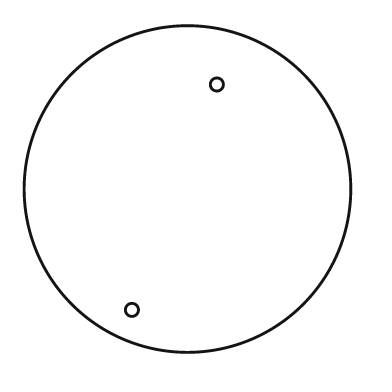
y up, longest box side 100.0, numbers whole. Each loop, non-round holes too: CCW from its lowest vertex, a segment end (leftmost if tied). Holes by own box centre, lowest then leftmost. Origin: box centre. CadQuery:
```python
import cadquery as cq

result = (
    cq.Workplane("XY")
    .moveTo(0.0, 0.0)
    .circle(50.0)
    .moveTo(-17.0, -37.0)
    .circle(2.0)
    .moveTo(9.0, 32.0)
    .circle(2.0)
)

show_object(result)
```